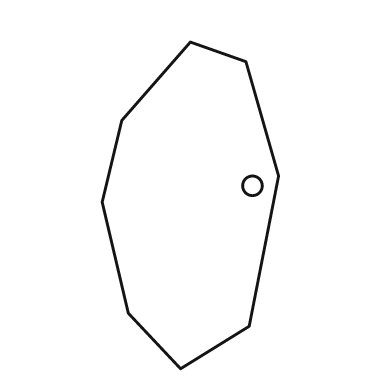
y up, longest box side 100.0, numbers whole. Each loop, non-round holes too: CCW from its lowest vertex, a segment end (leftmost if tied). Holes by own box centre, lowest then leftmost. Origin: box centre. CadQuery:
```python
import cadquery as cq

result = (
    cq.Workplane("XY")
    .moveTo(-3.0, -50.0)
    .lineTo(18.0, -37.0)
    .lineTo(27.0, 9.0)
    .lineTo(17.0, 44.0)
    .lineTo(0.0, 50.0)
    .lineTo(-21.0, 26.0)
    .lineTo(-27.0, 1.0)
    .lineTo(-19.0, -33.0)
    .close()
    .moveTo(19.0, 6.0)
    .circle(3.0)
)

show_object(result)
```